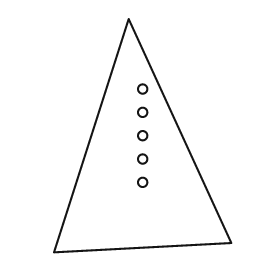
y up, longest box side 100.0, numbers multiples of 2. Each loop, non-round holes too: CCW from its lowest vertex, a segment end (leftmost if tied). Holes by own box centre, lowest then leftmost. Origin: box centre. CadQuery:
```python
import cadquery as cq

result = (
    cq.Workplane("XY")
    .moveTo(-38.0, -50.0)
    .lineTo(38.0, -46.0)
    .lineTo(-6.0, 50.0)
    .close()
    .moveTo(0.0, -20.0)
    .circle(2.0)
    .moveTo(0.0, -10.0)
    .circle(2.0)
    .moveTo(0.0, 0.0)
    .circle(2.0)
    .moveTo(0.0, 10.0)
    .circle(2.0)
    .moveTo(0.0, 20.0)
    .circle(2.0)
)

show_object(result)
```